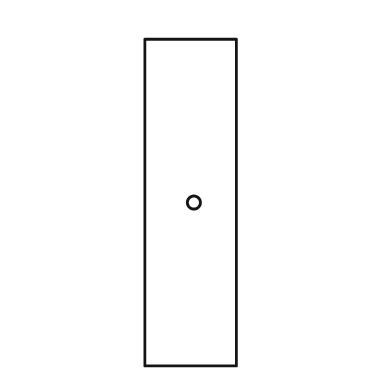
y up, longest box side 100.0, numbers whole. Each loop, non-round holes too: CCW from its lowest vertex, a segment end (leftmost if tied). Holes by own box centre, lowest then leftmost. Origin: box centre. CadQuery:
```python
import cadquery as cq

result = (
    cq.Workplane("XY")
    .moveTo(-14.0, -50.0)
    .lineTo(14.0, -50.0)
    .lineTo(14.0, 50.0)
    .lineTo(-14.0, 50.0)
    .close()
    .moveTo(1.0, 0.0)
    .circle(2.0)
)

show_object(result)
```